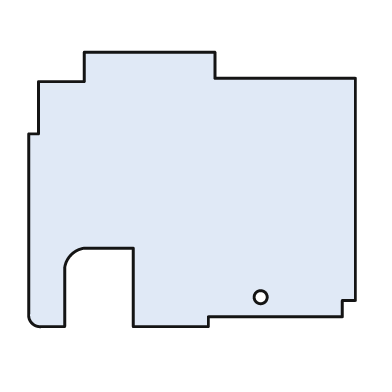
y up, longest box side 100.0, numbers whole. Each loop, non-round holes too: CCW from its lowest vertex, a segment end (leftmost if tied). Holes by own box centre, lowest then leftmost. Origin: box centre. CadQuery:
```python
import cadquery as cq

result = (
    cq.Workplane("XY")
    .moveTo(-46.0, -42.0)
    .lineTo(-39.0, -42.0)
    .lineTo(-39.0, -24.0)
    .threePointArc((-37.0, -20.0), (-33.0, -18.0))
    .lineTo(-18.0, -18.0)
    .lineTo(-18.0, -42.0)
    .lineTo(5.0, -42.0)
    .lineTo(5.0, -39.0)
    .lineTo(46.0, -39.0)
    .lineTo(46.0, -34.0)
    .lineTo(50.0, -34.0)
    .lineTo(50.0, 34.0)
    .lineTo(7.0, 34.0)
    .lineTo(7.0, 42.0)
    .lineTo(-33.0, 42.0)
    .lineTo(-33.0, 33.0)
    .lineTo(-47.0, 33.0)
    .lineTo(-47.0, 17.0)
    .lineTo(-50.0, 17.0)
    .lineTo(-50.0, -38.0)
    .threePointArc((-49.0, -41.0), (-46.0, -42.0))
    .close()
    .moveTo(21.0, -33.0)
    .circle(2.0)
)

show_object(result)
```